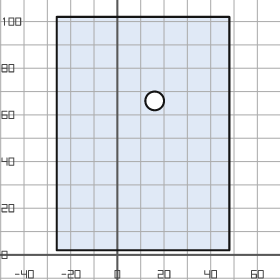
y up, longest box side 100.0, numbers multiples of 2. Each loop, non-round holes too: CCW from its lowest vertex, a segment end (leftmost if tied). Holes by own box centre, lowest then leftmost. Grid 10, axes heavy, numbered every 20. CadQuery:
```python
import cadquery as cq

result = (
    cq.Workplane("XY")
    .moveTo(-26.0, 2.0)
    .lineTo(48.0, 2.0)
    .lineTo(48.0, 102.0)
    .lineTo(-26.0, 102.0)
    .close()
    .moveTo(16.0, 66.0)
    .circle(4.0)
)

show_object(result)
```